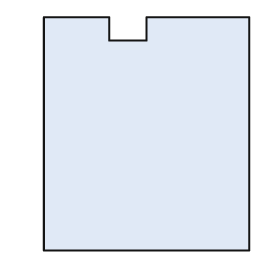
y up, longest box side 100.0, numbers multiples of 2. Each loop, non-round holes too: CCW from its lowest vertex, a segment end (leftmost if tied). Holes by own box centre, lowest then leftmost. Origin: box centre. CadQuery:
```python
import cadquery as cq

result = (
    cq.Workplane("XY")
    .moveTo(-44.0, -50.0)
    .lineTo(44.0, -50.0)
    .lineTo(44.0, 50.0)
    .lineTo(0.0, 50.0)
    .lineTo(0.0, 40.0)
    .lineTo(-16.0, 40.0)
    .lineTo(-16.0, 50.0)
    .lineTo(-44.0, 50.0)
    .close()
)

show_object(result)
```